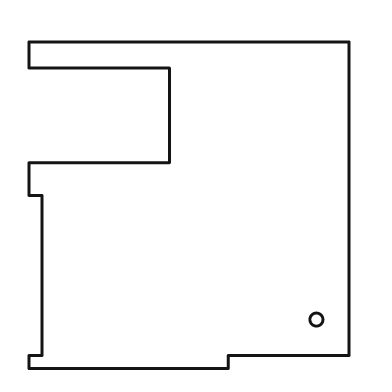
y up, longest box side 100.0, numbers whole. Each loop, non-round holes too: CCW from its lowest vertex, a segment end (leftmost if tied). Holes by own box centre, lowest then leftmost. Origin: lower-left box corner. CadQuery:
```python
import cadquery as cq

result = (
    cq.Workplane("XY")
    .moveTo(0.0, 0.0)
    .lineTo(61.0, 0.0)
    .lineTo(61.0, 4.0)
    .lineTo(98.0, 4.0)
    .lineTo(98.0, 100.0)
    .lineTo(0.0, 100.0)
    .lineTo(0.0, 92.0)
    .lineTo(43.0, 92.0)
    .lineTo(43.0, 63.0)
    .lineTo(0.0, 63.0)
    .lineTo(0.0, 53.0)
    .lineTo(4.0, 53.0)
    .lineTo(4.0, 4.0)
    .lineTo(0.0, 4.0)
    .close()
    .moveTo(88.0, 15.0)
    .circle(2.0)
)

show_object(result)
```